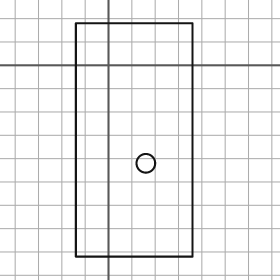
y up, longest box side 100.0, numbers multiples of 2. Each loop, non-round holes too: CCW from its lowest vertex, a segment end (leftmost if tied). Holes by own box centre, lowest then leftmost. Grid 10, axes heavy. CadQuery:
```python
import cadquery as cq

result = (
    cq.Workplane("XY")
    .moveTo(-14.0, -82.0)
    .lineTo(36.0, -82.0)
    .lineTo(36.0, 18.0)
    .lineTo(-14.0, 18.0)
    .close()
    .moveTo(16.0, -42.0)
    .circle(4.0)
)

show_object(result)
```